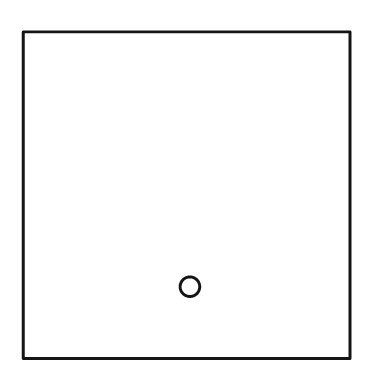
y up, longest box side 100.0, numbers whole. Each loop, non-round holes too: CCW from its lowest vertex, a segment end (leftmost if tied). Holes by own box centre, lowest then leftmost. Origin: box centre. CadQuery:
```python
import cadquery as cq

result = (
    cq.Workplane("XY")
    .moveTo(-50.0, -50.0)
    .lineTo(50.0, -50.0)
    .lineTo(50.0, 50.0)
    .lineTo(-50.0, 50.0)
    .close()
    .moveTo(1.0, -28.0)
    .circle(3.0)
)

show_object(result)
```